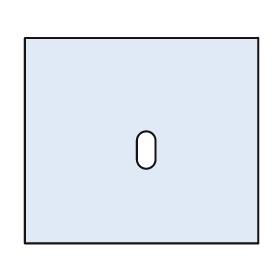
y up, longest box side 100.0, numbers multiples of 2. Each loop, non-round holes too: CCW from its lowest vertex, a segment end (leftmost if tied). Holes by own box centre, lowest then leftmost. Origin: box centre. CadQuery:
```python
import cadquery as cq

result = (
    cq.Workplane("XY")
    .moveTo(-50.0, -44.0)
    .lineTo(50.0, -44.0)
    .lineTo(50.0, 44.0)
    .lineTo(-50.0, 44.0)
    .close()
    .moveTo(-2.0, -8.0)
    .threePointArc((2.0, -12.0), (6.0, -8.0))
    .lineTo(6.0, 0.0)
    .threePointArc((2.0, 4.0), (-2.0, 0.0))
    .close()
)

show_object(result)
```